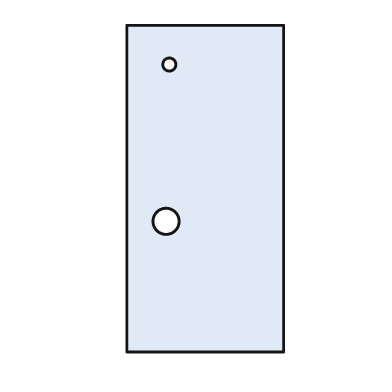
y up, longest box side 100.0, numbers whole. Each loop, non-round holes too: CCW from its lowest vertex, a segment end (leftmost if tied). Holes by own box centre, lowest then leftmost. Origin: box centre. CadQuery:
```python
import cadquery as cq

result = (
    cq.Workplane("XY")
    .moveTo(-24.0, -50.0)
    .lineTo(24.0, -50.0)
    .lineTo(24.0, 50.0)
    .lineTo(-24.0, 50.0)
    .close()
    .moveTo(-12.0, -10.0)
    .circle(4.0)
    .moveTo(-11.0, 38.0)
    .circle(2.0)
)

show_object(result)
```